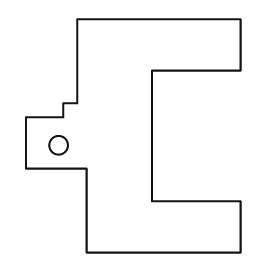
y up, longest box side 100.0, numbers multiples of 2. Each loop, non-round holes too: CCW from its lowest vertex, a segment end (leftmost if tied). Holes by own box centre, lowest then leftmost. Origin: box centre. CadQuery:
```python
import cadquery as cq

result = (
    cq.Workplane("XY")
    .moveTo(-20.0, -50.0)
    .lineTo(46.0, -50.0)
    .lineTo(46.0, -28.0)
    .lineTo(8.0, -28.0)
    .lineTo(8.0, 28.0)
    .lineTo(46.0, 28.0)
    .lineTo(46.0, 50.0)
    .lineTo(-24.0, 50.0)
    .lineTo(-24.0, 14.0)
    .lineTo(-30.0, 14.0)
    .lineTo(-30.0, 8.0)
    .lineTo(-46.0, 8.0)
    .lineTo(-46.0, -14.0)
    .lineTo(-20.0, -14.0)
    .close()
    .moveTo(-32.0, -4.0)
    .circle(4.0)
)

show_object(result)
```